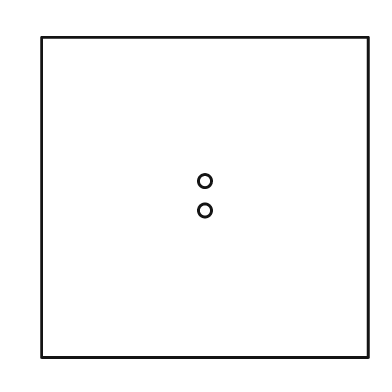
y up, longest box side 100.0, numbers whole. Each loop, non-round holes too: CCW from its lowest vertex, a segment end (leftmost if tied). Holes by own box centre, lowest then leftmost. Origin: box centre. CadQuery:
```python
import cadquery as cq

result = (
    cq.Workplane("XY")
    .moveTo(-50.0, -49.0)
    .lineTo(50.0, -49.0)
    .lineTo(50.0, 49.0)
    .lineTo(-50.0, 49.0)
    .close()
    .moveTo(0.0, -4.0)
    .circle(2.0)
    .moveTo(0.0, 5.0)
    .circle(2.0)
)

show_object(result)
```